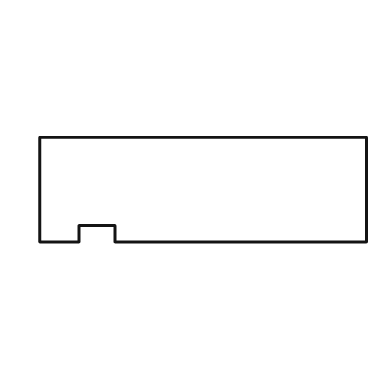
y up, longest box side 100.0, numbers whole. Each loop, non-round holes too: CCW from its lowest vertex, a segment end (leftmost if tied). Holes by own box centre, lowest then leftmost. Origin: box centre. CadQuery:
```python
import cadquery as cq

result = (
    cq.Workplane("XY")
    .moveTo(-50.0, -16.0)
    .lineTo(-38.0, -16.0)
    .lineTo(-38.0, -11.0)
    .lineTo(-27.0, -11.0)
    .lineTo(-27.0, -16.0)
    .lineTo(50.0, -16.0)
    .lineTo(50.0, 16.0)
    .lineTo(-50.0, 16.0)
    .close()
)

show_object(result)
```